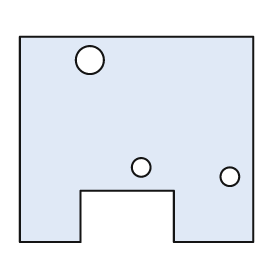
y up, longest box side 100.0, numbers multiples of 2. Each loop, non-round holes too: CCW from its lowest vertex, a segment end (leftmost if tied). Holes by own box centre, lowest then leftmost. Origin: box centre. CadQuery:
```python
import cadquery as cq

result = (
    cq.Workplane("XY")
    .moveTo(-50.0, -44.0)
    .lineTo(-24.0, -44.0)
    .lineTo(-24.0, -22.0)
    .lineTo(16.0, -22.0)
    .lineTo(16.0, -44.0)
    .lineTo(50.0, -44.0)
    .lineTo(50.0, 44.0)
    .lineTo(-50.0, 44.0)
    .close()
    .moveTo(40.0, -16.0)
    .circle(4.0)
    .moveTo(2.0, -12.0)
    .circle(4.0)
    .moveTo(-20.0, 34.0)
    .circle(6.0)
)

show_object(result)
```